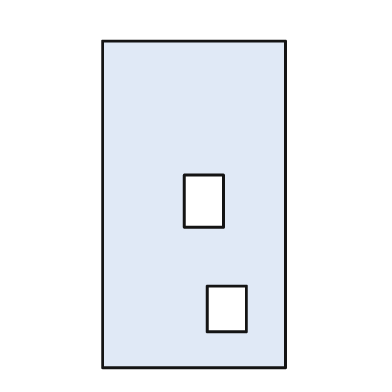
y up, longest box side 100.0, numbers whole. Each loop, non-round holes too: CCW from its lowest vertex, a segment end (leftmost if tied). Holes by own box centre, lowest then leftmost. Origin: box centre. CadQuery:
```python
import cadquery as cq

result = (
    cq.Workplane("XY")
    .moveTo(-28.0, -50.0)
    .lineTo(28.0, -50.0)
    .lineTo(28.0, 50.0)
    .lineTo(-28.0, 50.0)
    .close()
    .moveTo(4.0, -39.0)
    .lineTo(16.0, -39.0)
    .lineTo(16.0, -25.0)
    .lineTo(4.0, -25.0)
    .close()
    .moveTo(-3.0, -7.0)
    .lineTo(9.0, -7.0)
    .lineTo(9.0, 9.0)
    .lineTo(-3.0, 9.0)
    .close()
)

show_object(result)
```